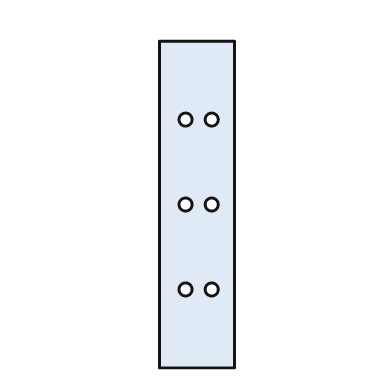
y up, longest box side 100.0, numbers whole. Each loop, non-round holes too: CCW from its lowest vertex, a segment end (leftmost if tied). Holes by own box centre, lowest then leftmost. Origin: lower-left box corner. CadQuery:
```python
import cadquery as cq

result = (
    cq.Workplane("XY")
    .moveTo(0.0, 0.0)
    .lineTo(23.0, 0.0)
    .lineTo(23.0, 100.0)
    .lineTo(0.0, 100.0)
    .close()
    .moveTo(8.0, 24.0)
    .circle(2.0)
    .moveTo(16.0, 24.0)
    .circle(2.0)
    .moveTo(8.0, 50.0)
    .circle(2.0)
    .moveTo(16.0, 50.0)
    .circle(2.0)
    .moveTo(8.0, 76.0)
    .circle(2.0)
    .moveTo(16.0, 76.0)
    .circle(2.0)
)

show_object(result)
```